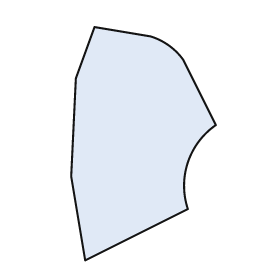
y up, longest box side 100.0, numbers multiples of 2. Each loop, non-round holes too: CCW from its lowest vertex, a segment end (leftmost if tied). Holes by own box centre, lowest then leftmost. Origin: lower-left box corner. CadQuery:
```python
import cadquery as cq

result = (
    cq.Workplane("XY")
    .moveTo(6.0, 0.0)
    .lineTo(50.0, 22.0)
    .threePointArc((50.0, 42.0), (62.0, 58.0))
    .lineTo(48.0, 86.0)
    .threePointArc((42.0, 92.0), (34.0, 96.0))
    .lineTo(10.0, 100.0)
    .lineTo(2.0, 78.0)
    .lineTo(0.0, 36.0)
    .close()
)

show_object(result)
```